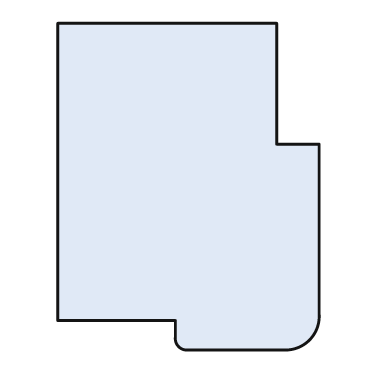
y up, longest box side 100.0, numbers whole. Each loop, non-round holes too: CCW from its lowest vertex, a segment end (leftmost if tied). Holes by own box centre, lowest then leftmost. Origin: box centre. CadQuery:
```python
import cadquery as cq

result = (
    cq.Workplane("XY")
    .moveTo(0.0, -50.0)
    .lineTo(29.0, -50.0)
    .threePointArc((37.0, -47.0), (40.0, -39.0))
    .lineTo(40.0, 13.0)
    .lineTo(27.0, 13.0)
    .lineTo(27.0, 50.0)
    .lineTo(-40.0, 50.0)
    .lineTo(-40.0, -41.0)
    .lineTo(-4.0, -41.0)
    .lineTo(-4.0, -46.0)
    .threePointArc((-3.0, -49.0), (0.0, -50.0))
    .close()
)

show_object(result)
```